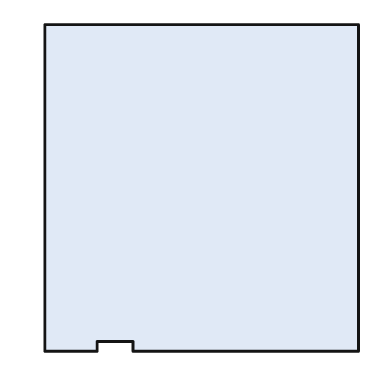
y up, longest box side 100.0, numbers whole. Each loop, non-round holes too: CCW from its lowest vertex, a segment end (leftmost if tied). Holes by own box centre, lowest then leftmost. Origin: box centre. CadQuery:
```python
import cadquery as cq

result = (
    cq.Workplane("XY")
    .moveTo(-48.0, -50.0)
    .lineTo(-32.0, -50.0)
    .lineTo(-32.0, -47.0)
    .lineTo(-21.0, -47.0)
    .lineTo(-21.0, -50.0)
    .lineTo(48.0, -50.0)
    .lineTo(48.0, 50.0)
    .lineTo(-48.0, 50.0)
    .close()
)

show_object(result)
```